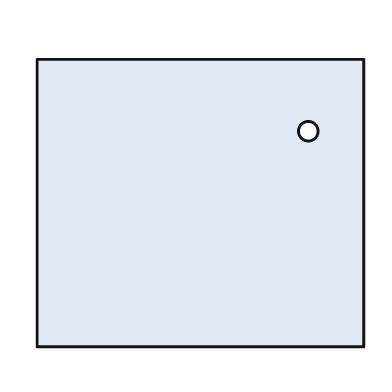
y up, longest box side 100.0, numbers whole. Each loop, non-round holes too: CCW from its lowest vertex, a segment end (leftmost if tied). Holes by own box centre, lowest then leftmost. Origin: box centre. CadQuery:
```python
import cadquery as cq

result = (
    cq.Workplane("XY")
    .moveTo(-50.0, -44.0)
    .lineTo(50.0, -44.0)
    .lineTo(50.0, 44.0)
    .lineTo(-50.0, 44.0)
    .close()
    .moveTo(33.0, 22.0)
    .circle(3.0)
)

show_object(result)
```